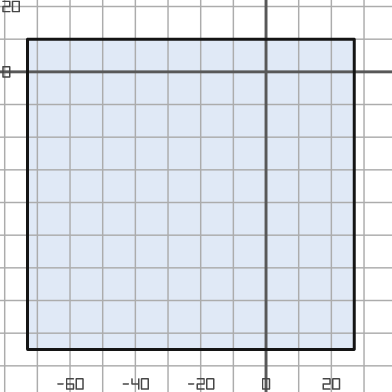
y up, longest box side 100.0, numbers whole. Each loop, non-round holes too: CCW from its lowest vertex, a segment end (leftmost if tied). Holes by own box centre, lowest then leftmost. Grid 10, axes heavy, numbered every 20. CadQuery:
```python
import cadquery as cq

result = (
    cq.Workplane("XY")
    .moveTo(-73.0, -85.0)
    .lineTo(27.0, -85.0)
    .lineTo(27.0, 10.0)
    .lineTo(-73.0, 10.0)
    .close()
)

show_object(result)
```